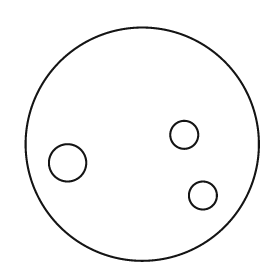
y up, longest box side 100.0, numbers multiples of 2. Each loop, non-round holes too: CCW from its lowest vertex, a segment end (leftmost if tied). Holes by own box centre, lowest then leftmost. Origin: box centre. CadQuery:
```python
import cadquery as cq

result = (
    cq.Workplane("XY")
    .moveTo(0.0, 0.0)
    .circle(50.0)
    .moveTo(26.0, -22.0)
    .circle(6.0)
    .moveTo(-32.0, -8.0)
    .circle(8.0)
    .moveTo(18.0, 4.0)
    .circle(6.0)
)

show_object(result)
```